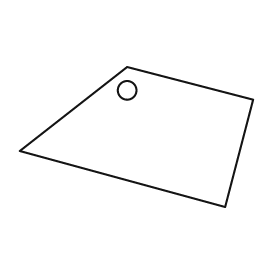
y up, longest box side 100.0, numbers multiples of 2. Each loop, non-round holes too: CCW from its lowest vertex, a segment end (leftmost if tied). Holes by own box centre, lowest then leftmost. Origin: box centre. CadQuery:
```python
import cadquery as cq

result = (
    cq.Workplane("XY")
    .moveTo(38.0, -30.0)
    .lineTo(50.0, 16.0)
    .lineTo(-4.0, 30.0)
    .lineTo(-50.0, -6.0)
    .close()
    .moveTo(-4.0, 20.0)
    .circle(4.0)
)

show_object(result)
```